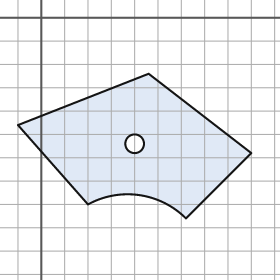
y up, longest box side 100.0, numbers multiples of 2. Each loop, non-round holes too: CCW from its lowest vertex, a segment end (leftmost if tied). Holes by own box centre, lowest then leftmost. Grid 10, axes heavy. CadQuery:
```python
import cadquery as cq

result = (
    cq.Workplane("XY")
    .moveTo(62.0, -86.0)
    .lineTo(90.0, -58.0)
    .lineTo(46.0, -24.0)
    .lineTo(-10.0, -46.0)
    .lineTo(20.0, -80.0)
    .threePointArc((42.0, -76.0), (62.0, -86.0))
    .close()
    .moveTo(40.0, -54.0)
    .circle(4.0)
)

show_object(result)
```